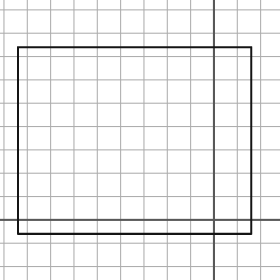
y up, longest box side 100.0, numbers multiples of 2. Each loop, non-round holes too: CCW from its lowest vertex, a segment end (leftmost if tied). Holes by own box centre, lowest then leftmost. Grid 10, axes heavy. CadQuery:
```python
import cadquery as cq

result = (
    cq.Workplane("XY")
    .moveTo(-84.0, -6.0)
    .lineTo(16.0, -6.0)
    .lineTo(16.0, 74.0)
    .lineTo(-84.0, 74.0)
    .close()
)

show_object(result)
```